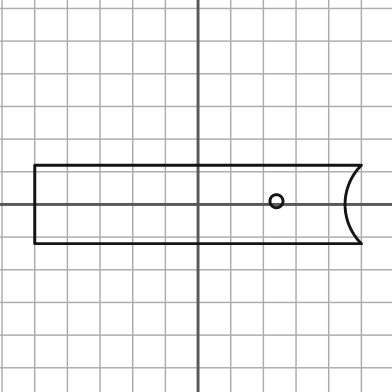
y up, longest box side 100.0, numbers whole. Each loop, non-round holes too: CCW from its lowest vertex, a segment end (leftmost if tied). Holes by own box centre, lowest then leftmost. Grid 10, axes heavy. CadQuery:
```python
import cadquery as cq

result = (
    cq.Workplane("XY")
    .moveTo(-50.0, -12.0)
    .lineTo(50.0, -12.0)
    .threePointArc((45.0, 0.0), (50.0, 12.0))
    .lineTo(-50.0, 12.0)
    .close()
    .moveTo(24.0, 1.0)
    .circle(2.0)
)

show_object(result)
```